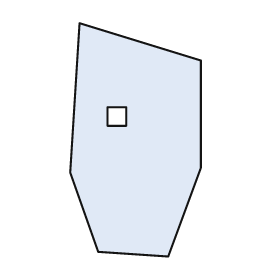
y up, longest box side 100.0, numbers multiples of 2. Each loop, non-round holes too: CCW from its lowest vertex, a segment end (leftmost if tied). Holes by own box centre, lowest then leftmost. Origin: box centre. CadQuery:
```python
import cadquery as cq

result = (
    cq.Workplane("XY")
    .moveTo(14.0, -50.0)
    .lineTo(28.0, -12.0)
    .lineTo(28.0, 34.0)
    .lineTo(-24.0, 50.0)
    .lineTo(-28.0, -14.0)
    .lineTo(-16.0, -48.0)
    .close()
    .moveTo(-12.0, 6.0)
    .lineTo(-4.0, 6.0)
    .lineTo(-4.0, 14.0)
    .lineTo(-12.0, 14.0)
    .close()
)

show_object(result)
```